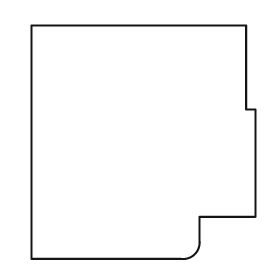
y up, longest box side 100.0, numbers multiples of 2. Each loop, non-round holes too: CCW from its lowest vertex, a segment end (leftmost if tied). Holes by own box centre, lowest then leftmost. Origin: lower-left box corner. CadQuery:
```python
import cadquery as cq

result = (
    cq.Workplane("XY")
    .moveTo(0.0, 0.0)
    .lineTo(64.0, 0.0)
    .threePointArc((70.0, 2.0), (72.0, 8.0))
    .lineTo(72.0, 18.0)
    .lineTo(96.0, 18.0)
    .lineTo(96.0, 64.0)
    .lineTo(92.0, 64.0)
    .lineTo(92.0, 100.0)
    .lineTo(0.0, 100.0)
    .close()
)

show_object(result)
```